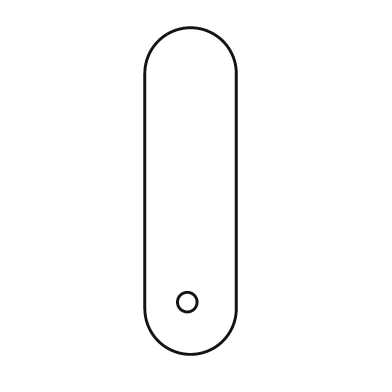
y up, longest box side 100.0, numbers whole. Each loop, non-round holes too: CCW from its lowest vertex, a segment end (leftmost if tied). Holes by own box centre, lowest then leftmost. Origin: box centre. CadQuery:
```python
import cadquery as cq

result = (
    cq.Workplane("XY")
    .moveTo(-14.0, -36.0)
    .threePointArc((0.0, -50.0), (14.0, -36.0))
    .lineTo(14.0, 36.0)
    .threePointArc((0.0, 50.0), (-14.0, 36.0))
    .close()
    .moveTo(-1.0, -34.0)
    .circle(3.0)
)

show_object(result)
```